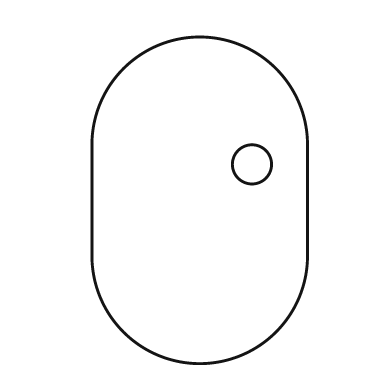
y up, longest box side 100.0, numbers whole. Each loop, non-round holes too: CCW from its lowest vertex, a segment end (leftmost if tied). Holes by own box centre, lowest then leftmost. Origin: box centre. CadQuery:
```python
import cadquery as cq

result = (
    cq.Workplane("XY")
    .moveTo(-33.0, -17.0)
    .threePointArc((0.0, -50.0), (33.0, -17.0))
    .lineTo(33.0, 17.0)
    .threePointArc((0.0, 50.0), (-33.0, 17.0))
    .close()
    .moveTo(16.0, 11.0)
    .circle(6.0)
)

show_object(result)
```